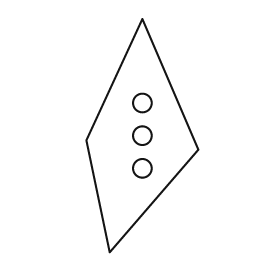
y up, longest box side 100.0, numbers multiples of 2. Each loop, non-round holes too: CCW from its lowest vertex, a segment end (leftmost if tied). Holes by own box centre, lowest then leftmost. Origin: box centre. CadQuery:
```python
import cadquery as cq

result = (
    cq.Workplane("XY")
    .moveTo(-14.0, -50.0)
    .lineTo(24.0, -6.0)
    .lineTo(0.0, 50.0)
    .lineTo(-24.0, -2.0)
    .close()
    .moveTo(0.0, -14.0)
    .circle(4.0)
    .moveTo(0.0, 0.0)
    .circle(4.0)
    .moveTo(0.0, 14.0)
    .circle(4.0)
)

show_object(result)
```